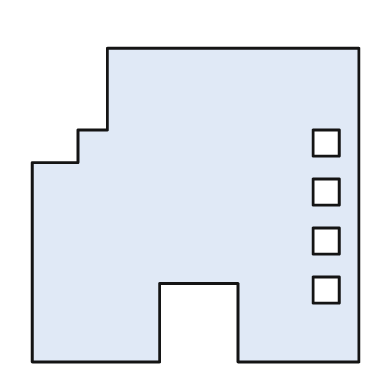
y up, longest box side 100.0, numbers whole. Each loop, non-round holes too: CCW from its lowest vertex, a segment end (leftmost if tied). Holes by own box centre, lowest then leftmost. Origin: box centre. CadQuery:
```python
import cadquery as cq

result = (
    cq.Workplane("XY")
    .moveTo(-50.0, -48.0)
    .lineTo(-11.0, -48.0)
    .lineTo(-11.0, -24.0)
    .lineTo(13.0, -24.0)
    .lineTo(13.0, -48.0)
    .lineTo(50.0, -48.0)
    .lineTo(50.0, 48.0)
    .lineTo(-27.0, 48.0)
    .lineTo(-27.0, 23.0)
    .lineTo(-36.0, 23.0)
    .lineTo(-36.0, 13.0)
    .lineTo(-50.0, 13.0)
    .close()
    .moveTo(36.0, -30.0)
    .lineTo(44.0, -30.0)
    .lineTo(44.0, -22.0)
    .lineTo(36.0, -22.0)
    .close()
    .moveTo(36.0, -15.0)
    .lineTo(44.0, -15.0)
    .lineTo(44.0, -7.0)
    .lineTo(36.0, -7.0)
    .close()
    .moveTo(36.0, 0.0)
    .lineTo(44.0, 0.0)
    .lineTo(44.0, 8.0)
    .lineTo(36.0, 8.0)
    .close()
    .moveTo(36.0, 15.0)
    .lineTo(44.0, 15.0)
    .lineTo(44.0, 23.0)
    .lineTo(36.0, 23.0)
    .close()
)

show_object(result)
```